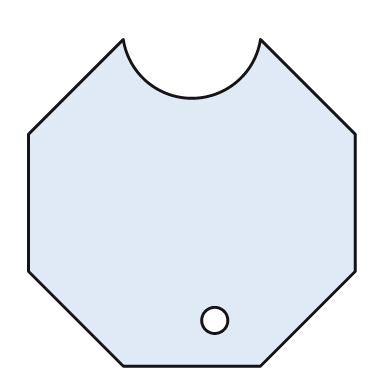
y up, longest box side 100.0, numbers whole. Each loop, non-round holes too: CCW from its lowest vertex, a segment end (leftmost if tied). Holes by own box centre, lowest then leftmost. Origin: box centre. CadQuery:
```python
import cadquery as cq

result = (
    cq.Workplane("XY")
    .moveTo(-21.0, -50.0)
    .lineTo(21.0, -50.0)
    .lineTo(50.0, -21.0)
    .lineTo(50.0, 21.0)
    .lineTo(21.0, 50.0)
    .threePointArc((0.0, 32.0), (-21.0, 50.0))
    .lineTo(-50.0, 21.0)
    .lineTo(-50.0, -21.0)
    .close()
    .moveTo(7.0, -36.0)
    .circle(4.0)
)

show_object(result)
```